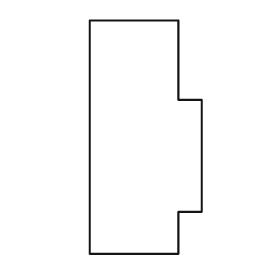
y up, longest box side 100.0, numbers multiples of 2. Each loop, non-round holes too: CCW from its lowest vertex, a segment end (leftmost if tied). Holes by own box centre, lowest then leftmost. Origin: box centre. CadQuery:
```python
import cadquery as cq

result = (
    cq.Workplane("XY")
    .moveTo(-24.0, -50.0)
    .lineTo(14.0, -50.0)
    .lineTo(14.0, -32.0)
    .lineTo(24.0, -32.0)
    .lineTo(24.0, 16.0)
    .lineTo(14.0, 16.0)
    .lineTo(14.0, 50.0)
    .lineTo(-24.0, 50.0)
    .close()
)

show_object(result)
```